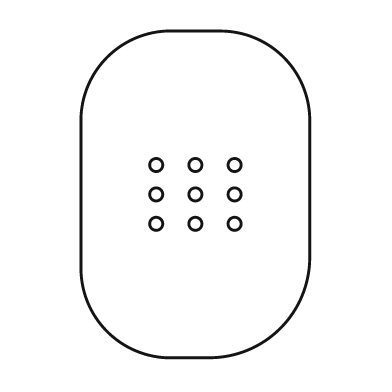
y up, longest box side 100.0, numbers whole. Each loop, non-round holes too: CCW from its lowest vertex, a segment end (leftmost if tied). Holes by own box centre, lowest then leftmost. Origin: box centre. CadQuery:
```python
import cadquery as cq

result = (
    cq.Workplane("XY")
    .moveTo(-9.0, -50.0)
    .lineTo(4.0, -50.0)
    .threePointArc((26.0, -41.0), (35.0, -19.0))
    .lineTo(35.0, 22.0)
    .threePointArc((27.0, 42.0), (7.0, 50.0))
    .lineTo(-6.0, 50.0)
    .threePointArc((-27.0, 42.0), (-35.0, 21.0))
    .lineTo(-35.0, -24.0)
    .threePointArc((-27.0, -42.0), (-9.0, -50.0))
    .close()
    .moveTo(-12.0, -9.0)
    .circle(2.0)
    .moveTo(0.0, -9.0)
    .circle(2.0)
    .moveTo(12.0, -9.0)
    .circle(2.0)
    .moveTo(-12.0, 0.0)
    .circle(2.0)
    .moveTo(0.0, 0.0)
    .circle(2.0)
    .moveTo(12.0, 0.0)
    .circle(2.0)
    .moveTo(-12.0, 9.0)
    .circle(2.0)
    .moveTo(0.0, 9.0)
    .circle(2.0)
    .moveTo(12.0, 9.0)
    .circle(2.0)
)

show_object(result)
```